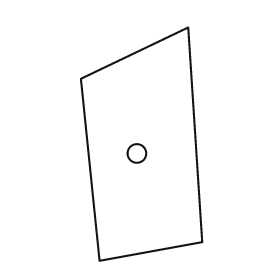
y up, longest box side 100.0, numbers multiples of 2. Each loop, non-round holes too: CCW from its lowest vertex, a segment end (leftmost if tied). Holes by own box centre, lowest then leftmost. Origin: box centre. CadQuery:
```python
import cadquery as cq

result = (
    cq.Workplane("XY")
    .moveTo(-18.0, -50.0)
    .lineTo(26.0, -42.0)
    .lineTo(20.0, 50.0)
    .lineTo(-26.0, 28.0)
    .close()
    .moveTo(-2.0, -4.0)
    .circle(4.0)
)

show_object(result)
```